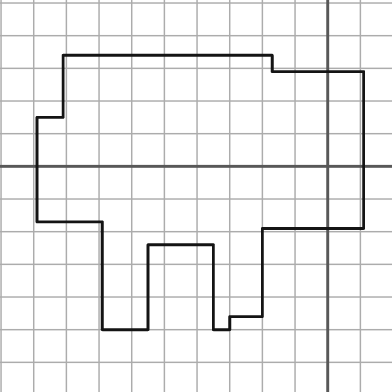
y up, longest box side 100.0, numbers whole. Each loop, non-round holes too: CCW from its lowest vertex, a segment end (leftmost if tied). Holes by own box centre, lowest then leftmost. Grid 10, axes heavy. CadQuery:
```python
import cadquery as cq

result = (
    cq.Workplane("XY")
    .moveTo(-69.0, -50.0)
    .lineTo(-55.0, -50.0)
    .lineTo(-55.0, -24.0)
    .lineTo(-35.0, -24.0)
    .lineTo(-35.0, -50.0)
    .lineTo(-30.0, -50.0)
    .lineTo(-30.0, -46.0)
    .lineTo(-20.0, -46.0)
    .lineTo(-20.0, -19.0)
    .lineTo(11.0, -19.0)
    .lineTo(11.0, 29.0)
    .lineTo(-17.0, 29.0)
    .lineTo(-17.0, 34.0)
    .lineTo(-81.0, 34.0)
    .lineTo(-81.0, 15.0)
    .lineTo(-89.0, 15.0)
    .lineTo(-89.0, -17.0)
    .lineTo(-69.0, -17.0)
    .close()
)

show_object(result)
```